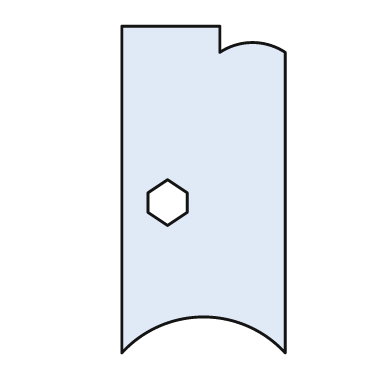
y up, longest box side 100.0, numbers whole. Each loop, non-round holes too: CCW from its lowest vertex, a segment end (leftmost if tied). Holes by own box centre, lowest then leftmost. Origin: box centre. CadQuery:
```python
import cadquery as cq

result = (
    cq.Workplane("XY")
    .moveTo(-25.0, -50.0)
    .threePointArc((0.0, -39.0), (25.0, -50.0))
    .lineTo(25.0, 42.0)
    .threePointArc((15.0, 45.0), (5.0, 42.0))
    .lineTo(5.0, 50.0)
    .lineTo(-25.0, 50.0)
    .close()
    .moveTo(-11.0, -11.0)
    .lineTo(-5.0, -7.0)
    .lineTo(-5.0, -1.0)
    .lineTo(-11.0, 3.0)
    .lineTo(-17.0, -1.0)
    .lineTo(-17.0, -7.0)
    .close()
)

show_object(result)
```